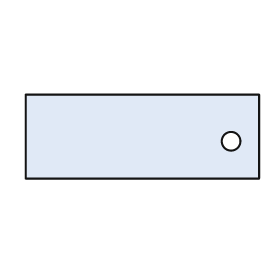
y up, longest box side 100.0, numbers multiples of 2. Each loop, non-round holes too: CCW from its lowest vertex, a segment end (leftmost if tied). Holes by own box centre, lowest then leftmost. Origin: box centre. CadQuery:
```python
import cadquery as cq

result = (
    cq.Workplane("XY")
    .moveTo(-50.0, -18.0)
    .lineTo(50.0, -18.0)
    .lineTo(50.0, 18.0)
    .lineTo(-50.0, 18.0)
    .close()
    .moveTo(38.0, -2.0)
    .circle(4.0)
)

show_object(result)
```